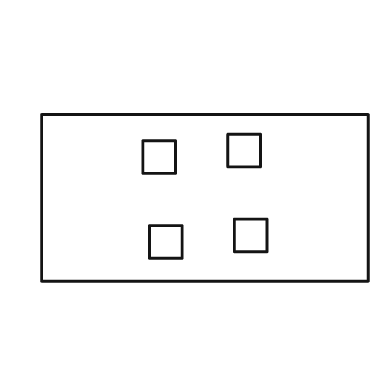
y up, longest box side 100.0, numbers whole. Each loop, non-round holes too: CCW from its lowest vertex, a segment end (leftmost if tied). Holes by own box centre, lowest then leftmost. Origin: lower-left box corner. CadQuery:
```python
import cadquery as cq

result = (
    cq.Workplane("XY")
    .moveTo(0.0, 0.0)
    .lineTo(100.0, 0.0)
    .lineTo(100.0, 51.0)
    .lineTo(0.0, 51.0)
    .close()
    .moveTo(33.0, 7.0)
    .lineTo(43.0, 7.0)
    .lineTo(43.0, 17.0)
    .lineTo(33.0, 17.0)
    .close()
    .moveTo(59.0, 9.0)
    .lineTo(69.0, 9.0)
    .lineTo(69.0, 19.0)
    .lineTo(59.0, 19.0)
    .close()
    .moveTo(31.0, 33.0)
    .lineTo(41.0, 33.0)
    .lineTo(41.0, 43.0)
    .lineTo(31.0, 43.0)
    .close()
    .moveTo(57.0, 35.0)
    .lineTo(67.0, 35.0)
    .lineTo(67.0, 45.0)
    .lineTo(57.0, 45.0)
    .close()
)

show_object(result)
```